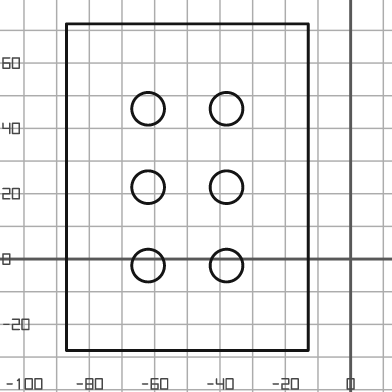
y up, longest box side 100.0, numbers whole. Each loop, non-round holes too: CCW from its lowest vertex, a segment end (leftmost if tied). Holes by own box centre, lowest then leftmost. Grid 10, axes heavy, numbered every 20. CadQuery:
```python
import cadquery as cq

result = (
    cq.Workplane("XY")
    .moveTo(-87.0, -28.0)
    .lineTo(-13.0, -28.0)
    .lineTo(-13.0, 72.0)
    .lineTo(-87.0, 72.0)
    .close()
    .moveTo(-62.0, -2.0)
    .circle(5.0)
    .moveTo(-38.0, -2.0)
    .circle(5.0)
    .moveTo(-62.0, 22.0)
    .circle(5.0)
    .moveTo(-38.0, 22.0)
    .circle(5.0)
    .moveTo(-62.0, 46.0)
    .circle(5.0)
    .moveTo(-38.0, 46.0)
    .circle(5.0)
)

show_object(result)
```